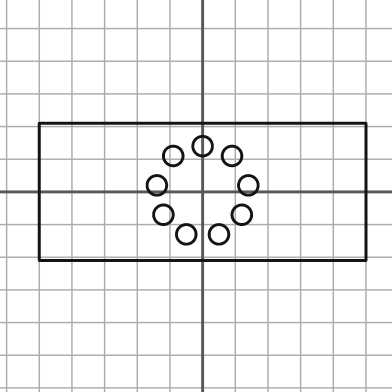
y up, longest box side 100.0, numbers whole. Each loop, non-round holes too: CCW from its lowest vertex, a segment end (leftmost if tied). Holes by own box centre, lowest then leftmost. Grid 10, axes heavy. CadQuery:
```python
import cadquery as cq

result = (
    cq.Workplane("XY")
    .moveTo(-50.0, -21.0)
    .lineTo(50.0, -21.0)
    .lineTo(50.0, 21.0)
    .lineTo(-50.0, 21.0)
    .close()
    .moveTo(-5.0, -13.0)
    .circle(3.0)
    .moveTo(5.0, -13.0)
    .circle(3.0)
    .moveTo(-12.0, -7.0)
    .circle(3.0)
    .moveTo(12.0, -7.0)
    .circle(3.0)
    .moveTo(-14.0, 2.0)
    .circle(3.0)
    .moveTo(14.0, 2.0)
    .circle(3.0)
    .moveTo(-9.0, 11.0)
    .circle(3.0)
    .moveTo(9.0, 11.0)
    .circle(3.0)
    .moveTo(0.0, 14.0)
    .circle(3.0)
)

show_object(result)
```